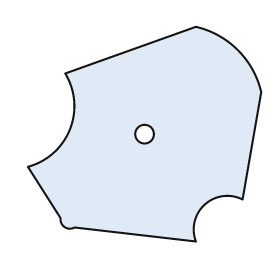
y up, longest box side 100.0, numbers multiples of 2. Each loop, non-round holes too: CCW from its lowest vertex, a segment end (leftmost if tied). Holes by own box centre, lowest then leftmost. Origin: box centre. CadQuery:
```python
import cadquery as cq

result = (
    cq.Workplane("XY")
    .moveTo(22.0, -46.0)
    .threePointArc((26.0, -30.0), (42.0, -28.0))
    .lineTo(50.0, 18.0)
    .threePointArc((40.0, 36.0), (22.0, 46.0))
    .lineTo(-34.0, 26.0)
    .threePointArc((-32.0, 2.0), (-50.0, -14.0))
    .lineTo(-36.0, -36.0)
    .threePointArc((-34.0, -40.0), (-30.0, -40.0))
    .close()
    .moveTo(0.0, 0.0)
    .circle(4.0)
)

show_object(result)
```